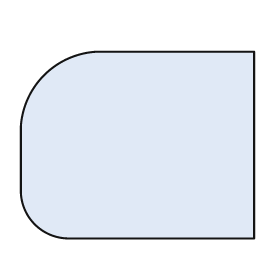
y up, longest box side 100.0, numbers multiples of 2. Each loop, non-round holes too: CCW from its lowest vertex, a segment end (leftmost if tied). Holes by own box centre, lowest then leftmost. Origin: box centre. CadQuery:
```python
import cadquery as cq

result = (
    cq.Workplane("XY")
    .moveTo(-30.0, -40.0)
    .lineTo(50.0, -40.0)
    .lineTo(50.0, 40.0)
    .lineTo(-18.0, 40.0)
    .threePointArc((-40.0, 30.0), (-50.0, 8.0))
    .lineTo(-50.0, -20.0)
    .threePointArc((-44.0, -34.0), (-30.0, -40.0))
    .close()
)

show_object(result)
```